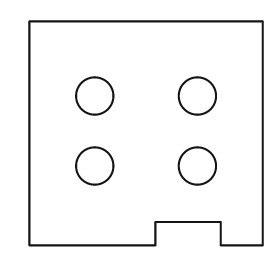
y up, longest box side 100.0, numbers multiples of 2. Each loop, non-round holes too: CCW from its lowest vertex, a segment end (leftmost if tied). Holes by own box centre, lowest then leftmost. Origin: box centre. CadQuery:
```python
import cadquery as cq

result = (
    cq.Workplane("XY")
    .moveTo(-50.0, -48.0)
    .lineTo(4.0, -48.0)
    .lineTo(4.0, -38.0)
    .lineTo(32.0, -38.0)
    .lineTo(32.0, -48.0)
    .lineTo(50.0, -48.0)
    .lineTo(50.0, 48.0)
    .lineTo(-50.0, 48.0)
    .close()
    .moveTo(-22.0, -14.0)
    .circle(8.0)
    .moveTo(22.0, -14.0)
    .circle(8.0)
    .moveTo(-22.0, 16.0)
    .circle(8.0)
    .moveTo(22.0, 16.0)
    .circle(8.0)
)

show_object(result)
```